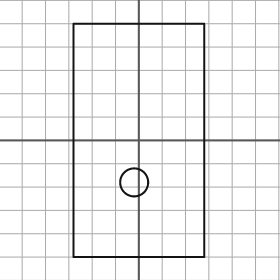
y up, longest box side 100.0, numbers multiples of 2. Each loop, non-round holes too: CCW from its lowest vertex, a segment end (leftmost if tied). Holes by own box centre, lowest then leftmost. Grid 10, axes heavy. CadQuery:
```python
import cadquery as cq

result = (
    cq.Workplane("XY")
    .moveTo(-28.0, -50.0)
    .lineTo(28.0, -50.0)
    .lineTo(28.0, 50.0)
    .lineTo(-28.0, 50.0)
    .close()
    .moveTo(-2.0, -18.0)
    .circle(6.0)
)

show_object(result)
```